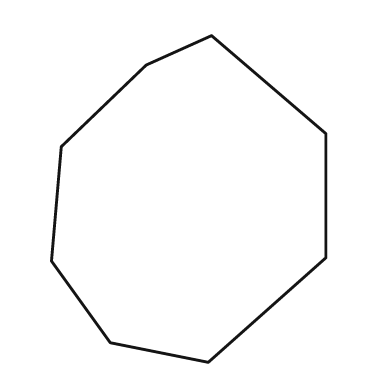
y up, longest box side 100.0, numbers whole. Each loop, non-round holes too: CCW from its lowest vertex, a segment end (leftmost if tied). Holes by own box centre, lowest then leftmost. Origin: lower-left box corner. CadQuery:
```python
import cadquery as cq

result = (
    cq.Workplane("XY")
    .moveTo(48.0, 0.0)
    .lineTo(84.0, 32.0)
    .lineTo(84.0, 70.0)
    .lineTo(49.0, 100.0)
    .lineTo(29.0, 91.0)
    .lineTo(3.0, 66.0)
    .lineTo(0.0, 31.0)
    .lineTo(18.0, 6.0)
    .close()
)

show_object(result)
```